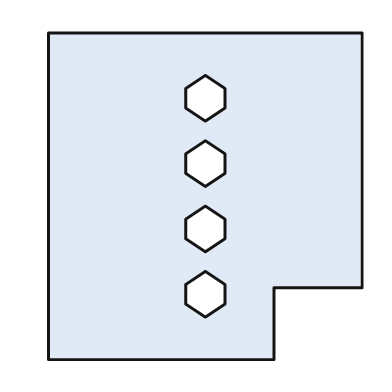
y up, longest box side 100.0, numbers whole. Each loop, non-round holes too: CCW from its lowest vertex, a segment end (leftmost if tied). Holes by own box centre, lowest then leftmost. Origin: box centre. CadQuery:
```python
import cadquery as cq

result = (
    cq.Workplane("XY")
    .moveTo(-48.0, -50.0)
    .lineTo(21.0, -50.0)
    .lineTo(21.0, -28.0)
    .lineTo(48.0, -28.0)
    .lineTo(48.0, 50.0)
    .lineTo(-48.0, 50.0)
    .close()
    .moveTo(0.0, -37.0)
    .lineTo(6.0, -33.0)
    .lineTo(6.0, -27.0)
    .lineTo(0.0, -23.0)
    .lineTo(-6.0, -27.0)
    .lineTo(-6.0, -33.0)
    .close()
    .moveTo(0.0, -17.0)
    .lineTo(6.0, -13.0)
    .lineTo(6.0, -7.0)
    .lineTo(0.0, -3.0)
    .lineTo(-6.0, -7.0)
    .lineTo(-6.0, -13.0)
    .close()
    .moveTo(0.0, 3.0)
    .lineTo(6.0, 7.0)
    .lineTo(6.0, 13.0)
    .lineTo(0.0, 17.0)
    .lineTo(-6.0, 13.0)
    .lineTo(-6.0, 7.0)
    .close()
    .moveTo(0.0, 23.0)
    .lineTo(6.0, 27.0)
    .lineTo(6.0, 33.0)
    .lineTo(0.0, 37.0)
    .lineTo(-6.0, 33.0)
    .lineTo(-6.0, 27.0)
    .close()
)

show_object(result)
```